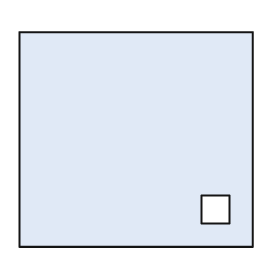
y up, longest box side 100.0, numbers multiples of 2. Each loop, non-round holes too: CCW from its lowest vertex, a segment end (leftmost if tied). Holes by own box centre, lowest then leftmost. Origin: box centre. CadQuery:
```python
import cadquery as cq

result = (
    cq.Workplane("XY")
    .moveTo(-50.0, -46.0)
    .lineTo(50.0, -46.0)
    .lineTo(50.0, 46.0)
    .lineTo(-50.0, 46.0)
    .close()
    .moveTo(28.0, -36.0)
    .lineTo(40.0, -36.0)
    .lineTo(40.0, -24.0)
    .lineTo(28.0, -24.0)
    .close()
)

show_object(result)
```